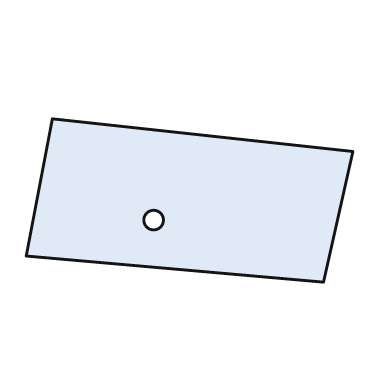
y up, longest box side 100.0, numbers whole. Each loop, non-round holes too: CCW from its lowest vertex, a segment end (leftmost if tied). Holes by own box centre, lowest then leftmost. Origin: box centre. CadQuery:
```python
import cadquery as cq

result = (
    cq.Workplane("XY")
    .moveTo(41.0, -25.0)
    .lineTo(50.0, 15.0)
    .lineTo(-42.0, 25.0)
    .lineTo(-50.0, -17.0)
    .close()
    .moveTo(-11.0, -6.0)
    .circle(3.0)
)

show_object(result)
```